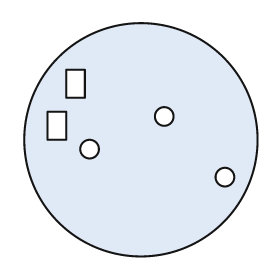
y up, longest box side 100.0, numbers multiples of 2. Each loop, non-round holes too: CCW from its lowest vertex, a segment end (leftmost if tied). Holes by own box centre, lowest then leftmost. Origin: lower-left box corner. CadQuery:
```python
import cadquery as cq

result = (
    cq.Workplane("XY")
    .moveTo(50.0, 50.0)
    .circle(50.0)
    .moveTo(86.0, 34.0)
    .circle(4.0)
    .moveTo(28.0, 46.0)
    .circle(4.0)
    .moveTo(10.0, 50.0)
    .lineTo(18.0, 50.0)
    .lineTo(18.0, 62.0)
    .lineTo(10.0, 62.0)
    .close()
    .moveTo(60.0, 60.0)
    .circle(4.0)
    .moveTo(18.0, 68.0)
    .lineTo(26.0, 68.0)
    .lineTo(26.0, 80.0)
    .lineTo(18.0, 80.0)
    .close()
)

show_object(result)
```